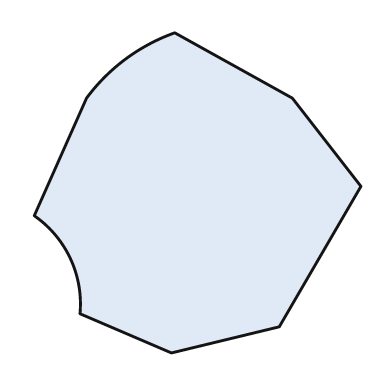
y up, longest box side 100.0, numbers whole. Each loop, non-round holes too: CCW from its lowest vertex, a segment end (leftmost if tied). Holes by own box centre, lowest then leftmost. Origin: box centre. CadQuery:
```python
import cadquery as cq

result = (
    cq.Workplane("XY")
    .moveTo(-8.0, -49.0)
    .lineTo(25.0, -41.0)
    .lineTo(50.0, 2.0)
    .lineTo(29.0, 29.0)
    .lineTo(-7.0, 49.0)
    .threePointArc((-22.0, 41.0), (-34.0, 29.0))
    .lineTo(-50.0, -7.0)
    .threePointArc((-39.0, -20.0), (-36.0, -37.0))
    .close()
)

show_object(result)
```